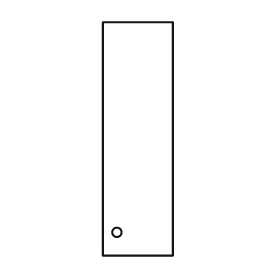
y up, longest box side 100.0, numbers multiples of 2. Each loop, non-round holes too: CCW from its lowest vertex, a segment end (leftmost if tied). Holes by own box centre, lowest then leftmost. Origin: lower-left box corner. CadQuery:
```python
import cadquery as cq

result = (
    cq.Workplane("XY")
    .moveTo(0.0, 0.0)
    .lineTo(30.0, 0.0)
    .lineTo(30.0, 100.0)
    .lineTo(0.0, 100.0)
    .close()
    .moveTo(6.0, 10.0)
    .circle(2.0)
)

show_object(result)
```